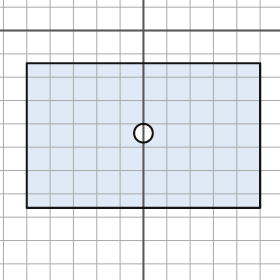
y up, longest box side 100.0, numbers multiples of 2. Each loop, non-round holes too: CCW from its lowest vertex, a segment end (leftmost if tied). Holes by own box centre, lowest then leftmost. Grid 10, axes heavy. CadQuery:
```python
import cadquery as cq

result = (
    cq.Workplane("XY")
    .moveTo(-50.0, -76.0)
    .lineTo(50.0, -76.0)
    .lineTo(50.0, -14.0)
    .lineTo(-50.0, -14.0)
    .close()
    .moveTo(0.0, -44.0)
    .circle(4.0)
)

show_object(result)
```